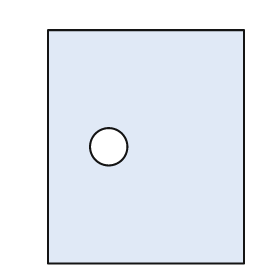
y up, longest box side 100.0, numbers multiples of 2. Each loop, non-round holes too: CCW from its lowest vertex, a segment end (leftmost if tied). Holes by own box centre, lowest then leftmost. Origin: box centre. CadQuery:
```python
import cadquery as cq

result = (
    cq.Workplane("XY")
    .moveTo(-42.0, -50.0)
    .lineTo(42.0, -50.0)
    .lineTo(42.0, 50.0)
    .lineTo(-42.0, 50.0)
    .close()
    .moveTo(-16.0, 0.0)
    .circle(8.0)
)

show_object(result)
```